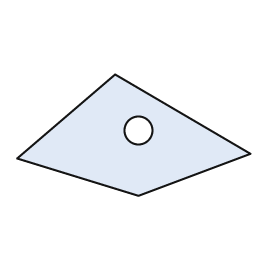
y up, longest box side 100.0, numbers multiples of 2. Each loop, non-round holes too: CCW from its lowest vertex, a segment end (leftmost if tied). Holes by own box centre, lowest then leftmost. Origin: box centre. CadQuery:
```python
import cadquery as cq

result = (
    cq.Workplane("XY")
    .moveTo(2.0, -26.0)
    .lineTo(50.0, -8.0)
    .lineTo(-8.0, 26.0)
    .lineTo(-50.0, -10.0)
    .close()
    .moveTo(2.0, 2.0)
    .circle(6.0)
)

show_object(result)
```